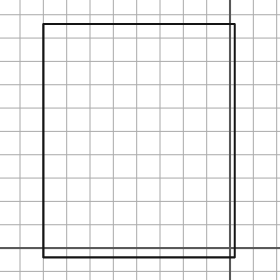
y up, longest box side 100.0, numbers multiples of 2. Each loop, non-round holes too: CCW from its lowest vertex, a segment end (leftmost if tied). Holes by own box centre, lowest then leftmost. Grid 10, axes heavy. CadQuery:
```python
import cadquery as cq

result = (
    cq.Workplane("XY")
    .moveTo(-80.0, -4.0)
    .lineTo(2.0, -4.0)
    .lineTo(2.0, 96.0)
    .lineTo(-80.0, 96.0)
    .close()
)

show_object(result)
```